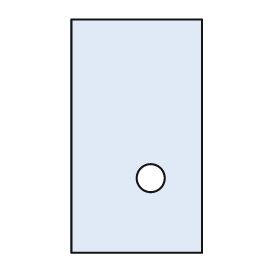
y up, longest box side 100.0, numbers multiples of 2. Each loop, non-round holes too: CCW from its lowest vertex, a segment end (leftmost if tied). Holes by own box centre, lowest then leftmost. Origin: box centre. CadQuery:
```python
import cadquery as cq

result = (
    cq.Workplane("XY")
    .moveTo(-28.0, -50.0)
    .lineTo(28.0, -50.0)
    .lineTo(28.0, 50.0)
    .lineTo(-28.0, 50.0)
    .close()
    .moveTo(6.0, -18.0)
    .circle(6.0)
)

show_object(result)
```